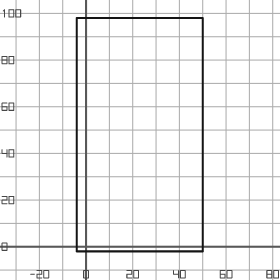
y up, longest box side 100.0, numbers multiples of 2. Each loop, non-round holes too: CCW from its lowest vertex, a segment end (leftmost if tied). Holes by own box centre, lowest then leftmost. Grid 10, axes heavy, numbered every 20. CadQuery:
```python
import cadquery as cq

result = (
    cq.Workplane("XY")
    .moveTo(-4.0, -2.0)
    .lineTo(50.0, -2.0)
    .lineTo(50.0, 98.0)
    .lineTo(-4.0, 98.0)
    .close()
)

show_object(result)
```